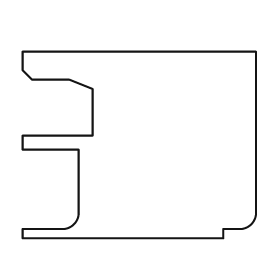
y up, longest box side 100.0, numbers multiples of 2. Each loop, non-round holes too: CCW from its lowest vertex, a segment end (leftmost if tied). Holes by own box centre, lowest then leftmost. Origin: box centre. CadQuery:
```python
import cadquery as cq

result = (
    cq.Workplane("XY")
    .moveTo(-50.0, -40.0)
    .lineTo(36.0, -40.0)
    .lineTo(36.0, -36.0)
    .lineTo(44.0, -36.0)
    .threePointArc((48.0, -34.0), (50.0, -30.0))
    .lineTo(50.0, 40.0)
    .lineTo(-50.0, 40.0)
    .lineTo(-50.0, 32.0)
    .lineTo(-46.0, 28.0)
    .lineTo(-30.0, 28.0)
    .lineTo(-20.0, 24.0)
    .lineTo(-20.0, 4.0)
    .lineTo(-50.0, 4.0)
    .lineTo(-50.0, -2.0)
    .lineTo(-26.0, -2.0)
    .lineTo(-26.0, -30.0)
    .threePointArc((-28.0, -34.0), (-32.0, -36.0))
    .lineTo(-50.0, -36.0)
    .close()
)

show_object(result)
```